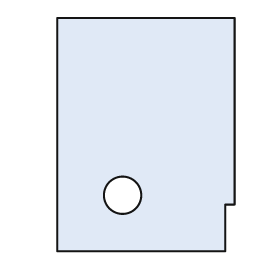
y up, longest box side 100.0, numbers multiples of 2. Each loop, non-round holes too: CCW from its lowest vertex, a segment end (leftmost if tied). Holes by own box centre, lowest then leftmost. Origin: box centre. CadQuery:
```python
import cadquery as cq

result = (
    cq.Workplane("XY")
    .moveTo(-38.0, -50.0)
    .lineTo(34.0, -50.0)
    .lineTo(34.0, -30.0)
    .lineTo(38.0, -30.0)
    .lineTo(38.0, 50.0)
    .lineTo(-38.0, 50.0)
    .close()
    .moveTo(-10.0, -26.0)
    .circle(8.0)
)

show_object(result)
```